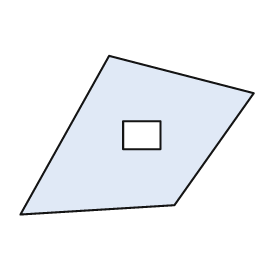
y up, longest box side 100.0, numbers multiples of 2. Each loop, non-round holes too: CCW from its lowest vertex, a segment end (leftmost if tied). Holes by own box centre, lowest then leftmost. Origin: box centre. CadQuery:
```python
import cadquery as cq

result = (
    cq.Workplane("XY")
    .moveTo(-50.0, -34.0)
    .lineTo(16.0, -30.0)
    .lineTo(50.0, 18.0)
    .lineTo(-12.0, 34.0)
    .close()
    .moveTo(-6.0, -6.0)
    .lineTo(10.0, -6.0)
    .lineTo(10.0, 6.0)
    .lineTo(-6.0, 6.0)
    .close()
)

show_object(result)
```